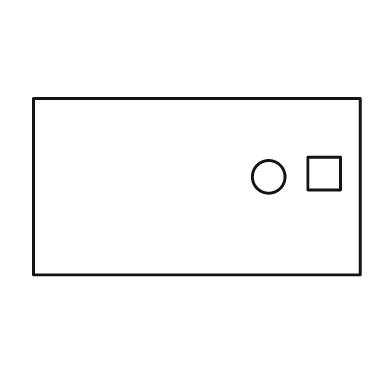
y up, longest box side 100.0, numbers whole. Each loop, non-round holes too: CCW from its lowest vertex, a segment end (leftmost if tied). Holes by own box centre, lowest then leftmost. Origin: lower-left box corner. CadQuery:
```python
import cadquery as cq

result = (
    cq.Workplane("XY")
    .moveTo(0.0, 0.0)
    .lineTo(100.0, 0.0)
    .lineTo(100.0, 54.0)
    .lineTo(0.0, 54.0)
    .close()
    .moveTo(72.0, 30.0)
    .circle(5.0)
    .moveTo(84.0, 26.0)
    .lineTo(94.0, 26.0)
    .lineTo(94.0, 36.0)
    .lineTo(84.0, 36.0)
    .close()
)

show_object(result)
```